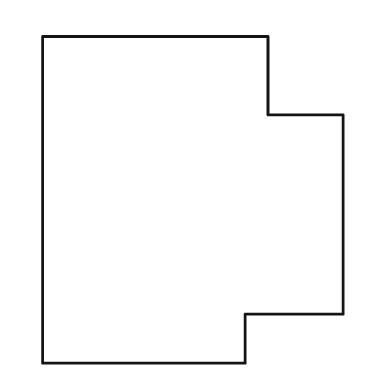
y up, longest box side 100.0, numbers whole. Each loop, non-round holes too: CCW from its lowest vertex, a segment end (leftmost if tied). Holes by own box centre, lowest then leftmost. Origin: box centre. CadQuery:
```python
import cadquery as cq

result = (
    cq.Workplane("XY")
    .moveTo(-46.0, -50.0)
    .lineTo(16.0, -50.0)
    .lineTo(16.0, -35.0)
    .lineTo(46.0, -35.0)
    .lineTo(46.0, 26.0)
    .lineTo(23.0, 26.0)
    .lineTo(23.0, 50.0)
    .lineTo(-46.0, 50.0)
    .close()
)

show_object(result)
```